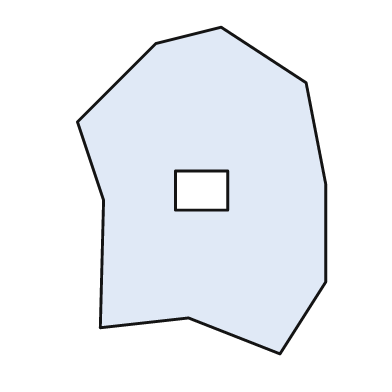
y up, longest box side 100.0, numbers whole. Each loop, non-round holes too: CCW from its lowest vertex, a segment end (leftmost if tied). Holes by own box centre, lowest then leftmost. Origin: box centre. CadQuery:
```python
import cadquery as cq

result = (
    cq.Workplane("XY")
    .moveTo(24.0, -50.0)
    .lineTo(38.0, -28.0)
    .lineTo(38.0, 2.0)
    .lineTo(32.0, 33.0)
    .lineTo(6.0, 50.0)
    .lineTo(-14.0, 45.0)
    .lineTo(-38.0, 21.0)
    .lineTo(-30.0, -3.0)
    .lineTo(-31.0, -42.0)
    .lineTo(-4.0, -39.0)
    .close()
    .moveTo(-8.0, -6.0)
    .lineTo(8.0, -6.0)
    .lineTo(8.0, 6.0)
    .lineTo(-8.0, 6.0)
    .close()
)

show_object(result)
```